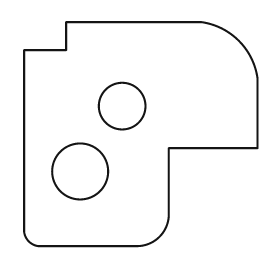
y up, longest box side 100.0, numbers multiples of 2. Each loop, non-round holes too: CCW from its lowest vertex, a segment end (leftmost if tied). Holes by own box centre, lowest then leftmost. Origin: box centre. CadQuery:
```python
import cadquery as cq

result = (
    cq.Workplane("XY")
    .moveTo(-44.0, -48.0)
    .lineTo(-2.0, -48.0)
    .threePointArc((8.0, -44.0), (12.0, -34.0))
    .lineTo(12.0, -6.0)
    .lineTo(50.0, -6.0)
    .lineTo(50.0, 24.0)
    .threePointArc((42.0, 40.0), (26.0, 48.0))
    .lineTo(-32.0, 48.0)
    .lineTo(-32.0, 36.0)
    .lineTo(-50.0, 36.0)
    .lineTo(-50.0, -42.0)
    .threePointArc((-48.0, -46.0), (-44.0, -48.0))
    .close()
    .moveTo(-26.0, -16.0)
    .circle(12.0)
    .moveTo(-8.0, 12.0)
    .circle(10.0)
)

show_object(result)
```